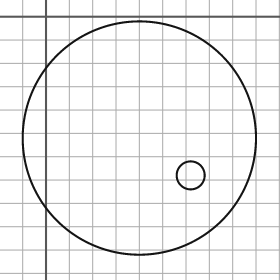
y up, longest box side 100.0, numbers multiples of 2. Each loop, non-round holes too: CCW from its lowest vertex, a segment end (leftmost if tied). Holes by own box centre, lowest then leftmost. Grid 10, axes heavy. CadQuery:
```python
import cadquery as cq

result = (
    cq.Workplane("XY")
    .moveTo(40.0, -52.0)
    .circle(50.0)
    .moveTo(62.0, -68.0)
    .circle(6.0)
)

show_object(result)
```